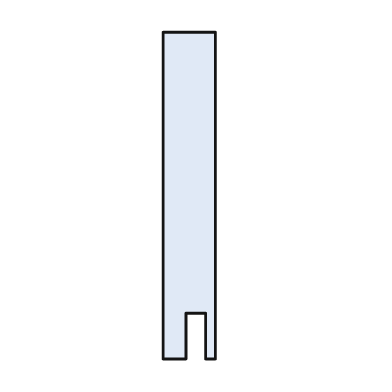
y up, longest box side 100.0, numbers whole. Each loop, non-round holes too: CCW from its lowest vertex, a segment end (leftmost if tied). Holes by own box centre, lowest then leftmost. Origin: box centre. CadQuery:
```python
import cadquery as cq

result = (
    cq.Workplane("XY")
    .moveTo(-8.0, -50.0)
    .lineTo(-1.0, -50.0)
    .lineTo(-1.0, -36.0)
    .lineTo(5.0, -36.0)
    .lineTo(5.0, -50.0)
    .lineTo(8.0, -50.0)
    .lineTo(8.0, 50.0)
    .lineTo(-8.0, 50.0)
    .close()
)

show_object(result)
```